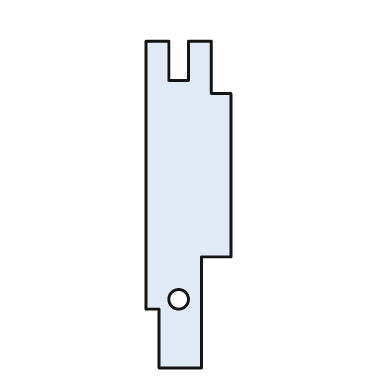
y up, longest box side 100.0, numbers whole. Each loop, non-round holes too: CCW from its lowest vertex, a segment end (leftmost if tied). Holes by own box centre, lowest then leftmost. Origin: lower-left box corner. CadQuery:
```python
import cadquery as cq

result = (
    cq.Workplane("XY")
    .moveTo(4.0, 0.0)
    .lineTo(17.0, 0.0)
    .lineTo(17.0, 34.0)
    .lineTo(26.0, 34.0)
    .lineTo(26.0, 84.0)
    .lineTo(20.0, 84.0)
    .lineTo(20.0, 100.0)
    .lineTo(13.0, 100.0)
    .lineTo(13.0, 88.0)
    .lineTo(7.0, 88.0)
    .lineTo(7.0, 100.0)
    .lineTo(0.0, 100.0)
    .lineTo(0.0, 18.0)
    .lineTo(4.0, 18.0)
    .close()
    .moveTo(10.0, 21.0)
    .circle(3.0)
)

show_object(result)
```